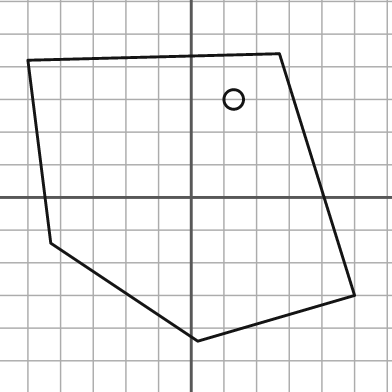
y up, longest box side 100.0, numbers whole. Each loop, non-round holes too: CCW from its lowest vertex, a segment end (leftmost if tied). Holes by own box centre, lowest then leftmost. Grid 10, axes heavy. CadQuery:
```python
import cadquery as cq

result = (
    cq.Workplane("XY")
    .moveTo(2.0, -44.0)
    .lineTo(50.0, -30.0)
    .lineTo(27.0, 44.0)
    .lineTo(-50.0, 42.0)
    .lineTo(-43.0, -14.0)
    .close()
    .moveTo(13.0, 30.0)
    .circle(3.0)
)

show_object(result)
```